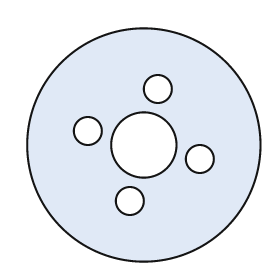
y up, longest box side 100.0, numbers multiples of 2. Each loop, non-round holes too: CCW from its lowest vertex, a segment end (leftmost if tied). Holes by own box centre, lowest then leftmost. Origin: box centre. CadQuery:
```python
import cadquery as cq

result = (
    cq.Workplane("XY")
    .moveTo(0.0, 0.0)
    .circle(50.0)
    .moveTo(-6.0, -24.0)
    .circle(6.0)
    .moveTo(24.0, -6.0)
    .circle(6.0)
    .moveTo(0.0, 0.0)
    .circle(14.0)
    .moveTo(-24.0, 6.0)
    .circle(6.0)
    .moveTo(6.0, 24.0)
    .circle(6.0)
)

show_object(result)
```